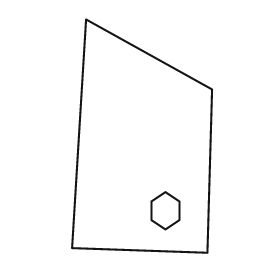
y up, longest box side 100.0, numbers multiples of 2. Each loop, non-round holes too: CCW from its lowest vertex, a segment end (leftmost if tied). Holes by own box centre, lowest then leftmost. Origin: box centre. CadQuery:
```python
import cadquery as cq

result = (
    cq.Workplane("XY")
    .moveTo(28.0, -50.0)
    .lineTo(30.0, 20.0)
    .lineTo(-24.0, 50.0)
    .lineTo(-30.0, -48.0)
    .close()
    .moveTo(10.0, -40.0)
    .lineTo(16.0, -36.0)
    .lineTo(16.0, -28.0)
    .lineTo(10.0, -24.0)
    .lineTo(4.0, -28.0)
    .lineTo(4.0, -36.0)
    .close()
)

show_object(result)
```